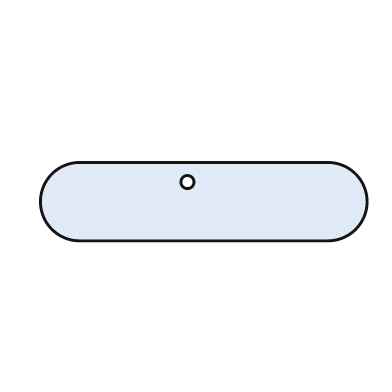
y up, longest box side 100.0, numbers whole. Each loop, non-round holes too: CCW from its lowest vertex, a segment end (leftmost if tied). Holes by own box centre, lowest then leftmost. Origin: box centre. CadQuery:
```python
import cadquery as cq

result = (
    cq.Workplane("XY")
    .moveTo(-38.0, -12.0)
    .lineTo(38.0, -12.0)
    .threePointArc((50.0, 0.0), (38.0, 12.0))
    .lineTo(-38.0, 12.0)
    .threePointArc((-50.0, 0.0), (-38.0, -12.0))
    .close()
    .moveTo(-5.0, 6.0)
    .circle(2.0)
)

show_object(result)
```